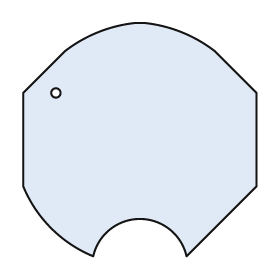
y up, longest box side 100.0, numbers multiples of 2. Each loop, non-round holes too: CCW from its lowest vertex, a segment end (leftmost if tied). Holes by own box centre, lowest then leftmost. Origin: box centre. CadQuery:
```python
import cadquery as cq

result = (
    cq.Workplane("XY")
    .moveTo(-20.0, -50.0)
    .threePointArc((0.0, -34.0), (20.0, -50.0))
    .lineTo(50.0, -20.0)
    .lineTo(50.0, 20.0)
    .lineTo(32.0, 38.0)
    .threePointArc((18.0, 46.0), (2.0, 50.0))
    .lineTo(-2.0, 50.0)
    .threePointArc((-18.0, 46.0), (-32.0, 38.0))
    .lineTo(-50.0, 20.0)
    .lineTo(-50.0, -20.0)
    .threePointArc((-38.0, -38.0), (-20.0, -50.0))
    .close()
    .moveTo(-36.0, 20.0)
    .circle(2.0)
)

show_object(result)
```